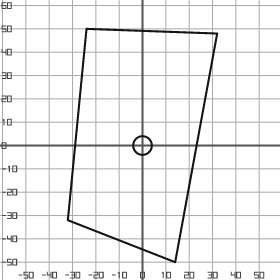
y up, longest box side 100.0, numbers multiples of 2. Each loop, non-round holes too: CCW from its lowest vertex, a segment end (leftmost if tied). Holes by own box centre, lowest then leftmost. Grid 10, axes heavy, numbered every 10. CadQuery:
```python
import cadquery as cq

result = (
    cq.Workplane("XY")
    .moveTo(14.0, -50.0)
    .lineTo(32.0, 48.0)
    .lineTo(-24.0, 50.0)
    .lineTo(-32.0, -32.0)
    .close()
    .moveTo(0.0, 0.0)
    .circle(4.0)
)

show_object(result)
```